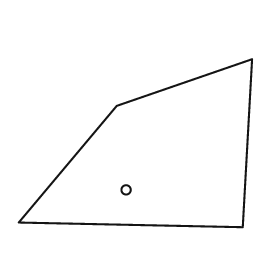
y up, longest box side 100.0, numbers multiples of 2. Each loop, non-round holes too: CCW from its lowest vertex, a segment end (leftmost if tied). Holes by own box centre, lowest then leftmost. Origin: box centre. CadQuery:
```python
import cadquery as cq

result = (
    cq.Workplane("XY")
    .moveTo(46.0, -36.0)
    .lineTo(50.0, 36.0)
    .lineTo(-8.0, 16.0)
    .lineTo(-50.0, -34.0)
    .close()
    .moveTo(-4.0, -20.0)
    .circle(2.0)
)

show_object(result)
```